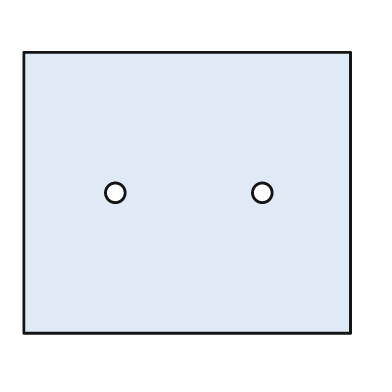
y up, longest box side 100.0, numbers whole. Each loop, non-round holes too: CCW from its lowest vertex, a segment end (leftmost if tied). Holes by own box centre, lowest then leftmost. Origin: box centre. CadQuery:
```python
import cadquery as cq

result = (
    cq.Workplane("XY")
    .moveTo(-50.0, -43.0)
    .lineTo(50.0, -43.0)
    .lineTo(50.0, 43.0)
    .lineTo(-50.0, 43.0)
    .close()
    .moveTo(-22.0, 0.0)
    .circle(3.0)
    .moveTo(23.0, 0.0)
    .circle(3.0)
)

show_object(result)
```